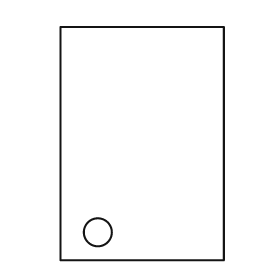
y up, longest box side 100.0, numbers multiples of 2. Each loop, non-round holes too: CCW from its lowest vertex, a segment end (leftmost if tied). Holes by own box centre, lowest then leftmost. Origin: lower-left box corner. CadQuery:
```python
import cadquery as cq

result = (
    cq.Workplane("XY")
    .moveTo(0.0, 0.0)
    .lineTo(70.0, 0.0)
    .lineTo(70.0, 100.0)
    .lineTo(0.0, 100.0)
    .close()
    .moveTo(16.0, 12.0)
    .circle(6.0)
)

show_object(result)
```